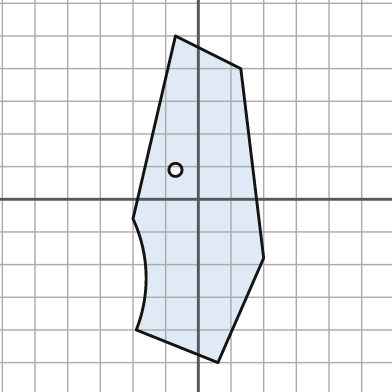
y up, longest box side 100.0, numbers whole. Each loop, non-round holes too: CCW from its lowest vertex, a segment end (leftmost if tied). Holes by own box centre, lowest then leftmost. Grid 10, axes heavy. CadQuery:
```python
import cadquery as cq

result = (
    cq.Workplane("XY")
    .moveTo(6.0, -50.0)
    .lineTo(20.0, -18.0)
    .lineTo(13.0, 40.0)
    .lineTo(-7.0, 50.0)
    .lineTo(-20.0, -6.0)
    .threePointArc((-16.0, -23.0), (-19.0, -40.0))
    .close()
    .moveTo(-7.0, 9.0)
    .circle(2.0)
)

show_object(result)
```